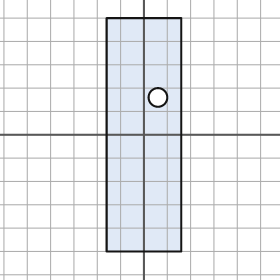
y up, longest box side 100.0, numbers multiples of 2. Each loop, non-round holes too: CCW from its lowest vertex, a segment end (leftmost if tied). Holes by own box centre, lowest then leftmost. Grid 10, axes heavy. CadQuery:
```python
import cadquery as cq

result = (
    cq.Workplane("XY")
    .moveTo(-16.0, -50.0)
    .lineTo(16.0, -50.0)
    .lineTo(16.0, 50.0)
    .lineTo(-16.0, 50.0)
    .close()
    .moveTo(6.0, 16.0)
    .circle(4.0)
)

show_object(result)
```